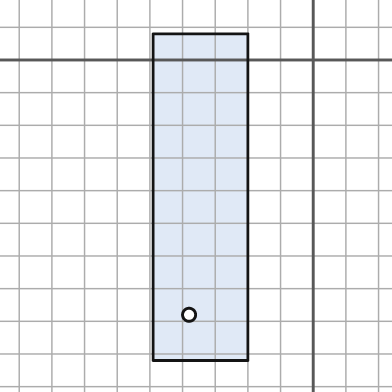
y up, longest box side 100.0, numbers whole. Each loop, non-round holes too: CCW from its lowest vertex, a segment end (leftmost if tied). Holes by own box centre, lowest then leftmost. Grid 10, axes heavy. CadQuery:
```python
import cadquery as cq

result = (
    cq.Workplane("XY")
    .moveTo(-49.0, -92.0)
    .lineTo(-20.0, -92.0)
    .lineTo(-20.0, 8.0)
    .lineTo(-49.0, 8.0)
    .close()
    .moveTo(-38.0, -78.0)
    .circle(2.0)
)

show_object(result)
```